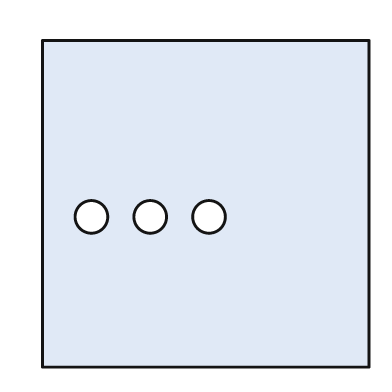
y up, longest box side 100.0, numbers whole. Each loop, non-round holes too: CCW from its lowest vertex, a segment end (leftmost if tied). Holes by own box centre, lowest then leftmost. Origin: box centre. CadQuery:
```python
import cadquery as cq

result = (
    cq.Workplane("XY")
    .moveTo(-50.0, -50.0)
    .lineTo(50.0, -50.0)
    .lineTo(50.0, 50.0)
    .lineTo(-50.0, 50.0)
    .close()
    .moveTo(-35.0, -4.0)
    .circle(5.0)
    .moveTo(-17.0, -4.0)
    .circle(5.0)
    .moveTo(1.0, -4.0)
    .circle(5.0)
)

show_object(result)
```